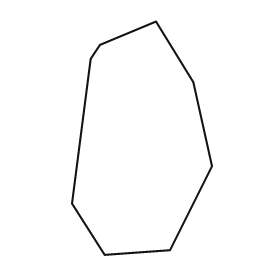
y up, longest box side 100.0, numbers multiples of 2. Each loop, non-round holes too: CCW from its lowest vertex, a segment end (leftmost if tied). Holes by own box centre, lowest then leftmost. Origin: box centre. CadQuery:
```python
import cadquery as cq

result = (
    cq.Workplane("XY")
    .moveTo(-16.0, -50.0)
    .lineTo(12.0, -48.0)
    .lineTo(30.0, -12.0)
    .lineTo(22.0, 24.0)
    .lineTo(6.0, 50.0)
    .lineTo(-18.0, 40.0)
    .lineTo(-22.0, 34.0)
    .lineTo(-30.0, -28.0)
    .close()
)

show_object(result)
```